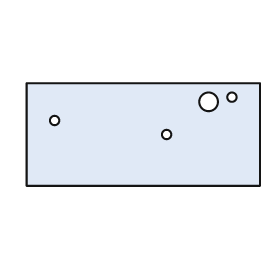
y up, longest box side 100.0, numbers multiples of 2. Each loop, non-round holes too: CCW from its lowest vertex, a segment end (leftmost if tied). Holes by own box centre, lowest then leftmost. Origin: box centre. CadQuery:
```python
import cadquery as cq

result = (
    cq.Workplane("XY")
    .moveTo(-50.0, -22.0)
    .lineTo(50.0, -22.0)
    .lineTo(50.0, 22.0)
    .lineTo(-50.0, 22.0)
    .close()
    .moveTo(10.0, 0.0)
    .circle(2.0)
    .moveTo(-38.0, 6.0)
    .circle(2.0)
    .moveTo(28.0, 14.0)
    .circle(4.0)
    .moveTo(38.0, 16.0)
    .circle(2.0)
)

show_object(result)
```